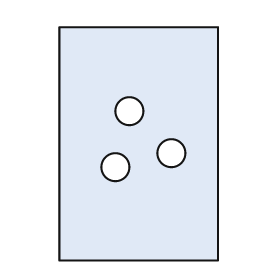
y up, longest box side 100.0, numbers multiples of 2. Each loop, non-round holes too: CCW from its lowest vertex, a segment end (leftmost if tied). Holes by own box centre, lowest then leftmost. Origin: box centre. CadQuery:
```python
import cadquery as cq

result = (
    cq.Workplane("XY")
    .moveTo(-34.0, -50.0)
    .lineTo(34.0, -50.0)
    .lineTo(34.0, 50.0)
    .lineTo(-34.0, 50.0)
    .close()
    .moveTo(-10.0, -10.0)
    .circle(6.0)
    .moveTo(14.0, -4.0)
    .circle(6.0)
    .moveTo(-4.0, 14.0)
    .circle(6.0)
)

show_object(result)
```